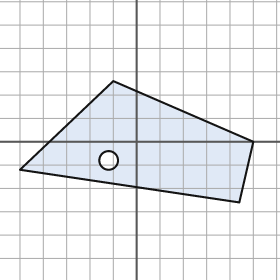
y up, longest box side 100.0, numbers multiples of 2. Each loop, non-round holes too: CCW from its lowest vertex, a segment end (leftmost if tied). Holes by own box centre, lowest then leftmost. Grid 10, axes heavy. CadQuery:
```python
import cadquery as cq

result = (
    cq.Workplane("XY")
    .moveTo(44.0, -26.0)
    .lineTo(50.0, 0.0)
    .lineTo(-10.0, 26.0)
    .lineTo(-50.0, -12.0)
    .close()
    .moveTo(-12.0, -8.0)
    .circle(4.0)
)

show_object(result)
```